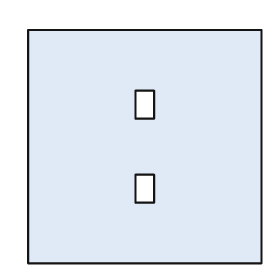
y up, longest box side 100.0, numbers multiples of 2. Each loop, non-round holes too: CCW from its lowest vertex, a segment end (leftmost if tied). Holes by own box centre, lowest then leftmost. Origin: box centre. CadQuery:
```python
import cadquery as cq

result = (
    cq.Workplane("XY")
    .moveTo(-50.0, -50.0)
    .lineTo(50.0, -50.0)
    .lineTo(50.0, 50.0)
    .lineTo(-50.0, 50.0)
    .close()
    .moveTo(-4.0, -24.0)
    .lineTo(4.0, -24.0)
    .lineTo(4.0, -12.0)
    .lineTo(-4.0, -12.0)
    .close()
    .moveTo(-4.0, 12.0)
    .lineTo(4.0, 12.0)
    .lineTo(4.0, 24.0)
    .lineTo(-4.0, 24.0)
    .close()
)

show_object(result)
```